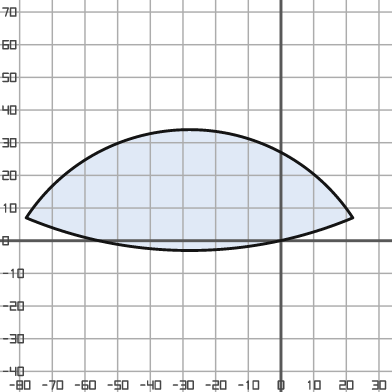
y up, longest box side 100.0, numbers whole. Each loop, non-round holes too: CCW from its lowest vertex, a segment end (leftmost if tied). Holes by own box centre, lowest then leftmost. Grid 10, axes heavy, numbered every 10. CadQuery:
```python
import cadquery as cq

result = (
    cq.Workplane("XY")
    .moveTo(-78.0, 7.0)
    .threePointArc((-28.0, -3.0), (22.0, 7.0))
    .threePointArc((-28.0, 34.0), (-78.0, 7.0))
    .close()
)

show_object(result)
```